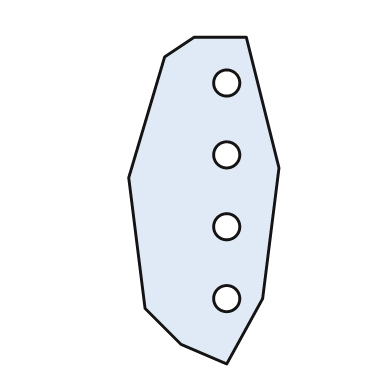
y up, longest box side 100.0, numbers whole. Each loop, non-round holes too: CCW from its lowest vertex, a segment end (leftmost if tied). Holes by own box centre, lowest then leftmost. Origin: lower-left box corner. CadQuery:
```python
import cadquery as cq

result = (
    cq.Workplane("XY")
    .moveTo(30.0, 0.0)
    .lineTo(41.0, 20.0)
    .lineTo(46.0, 60.0)
    .lineTo(36.0, 100.0)
    .lineTo(20.0, 100.0)
    .lineTo(11.0, 94.0)
    .lineTo(0.0, 57.0)
    .lineTo(5.0, 17.0)
    .lineTo(16.0, 6.0)
    .close()
    .moveTo(30.0, 20.0)
    .circle(4.0)
    .moveTo(30.0, 42.0)
    .circle(4.0)
    .moveTo(30.0, 64.0)
    .circle(4.0)
    .moveTo(30.0, 86.0)
    .circle(4.0)
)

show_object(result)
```